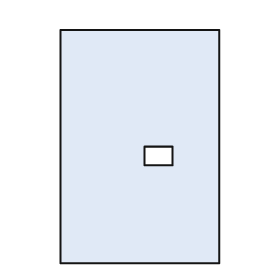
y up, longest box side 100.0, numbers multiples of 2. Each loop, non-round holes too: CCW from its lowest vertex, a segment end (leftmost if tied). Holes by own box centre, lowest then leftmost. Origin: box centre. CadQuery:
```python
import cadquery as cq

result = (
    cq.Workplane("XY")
    .moveTo(-34.0, -50.0)
    .lineTo(34.0, -50.0)
    .lineTo(34.0, 50.0)
    .lineTo(-34.0, 50.0)
    .close()
    .moveTo(2.0, -8.0)
    .lineTo(14.0, -8.0)
    .lineTo(14.0, 0.0)
    .lineTo(2.0, 0.0)
    .close()
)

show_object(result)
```